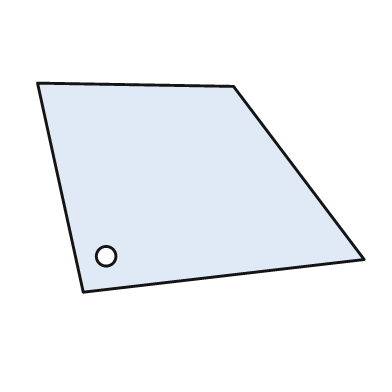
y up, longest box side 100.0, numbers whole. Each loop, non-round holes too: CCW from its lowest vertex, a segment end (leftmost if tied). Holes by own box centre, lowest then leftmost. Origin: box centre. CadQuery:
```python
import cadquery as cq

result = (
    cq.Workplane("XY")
    .moveTo(-36.0, -32.0)
    .lineTo(50.0, -22.0)
    .lineTo(10.0, 31.0)
    .lineTo(-50.0, 32.0)
    .close()
    .moveTo(-29.0, -21.0)
    .circle(3.0)
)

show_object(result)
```